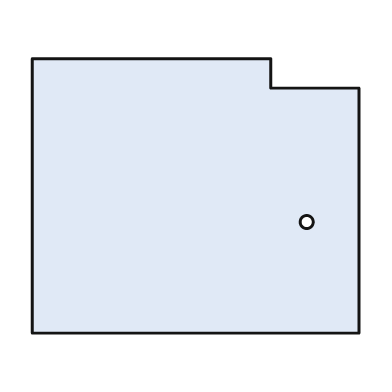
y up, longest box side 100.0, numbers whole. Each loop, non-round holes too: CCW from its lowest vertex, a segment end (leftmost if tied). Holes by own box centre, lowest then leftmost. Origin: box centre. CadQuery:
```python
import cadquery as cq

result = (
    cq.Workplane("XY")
    .moveTo(-50.0, -42.0)
    .lineTo(50.0, -42.0)
    .lineTo(50.0, 33.0)
    .lineTo(23.0, 33.0)
    .lineTo(23.0, 42.0)
    .lineTo(-50.0, 42.0)
    .close()
    .moveTo(34.0, -8.0)
    .circle(2.0)
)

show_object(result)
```